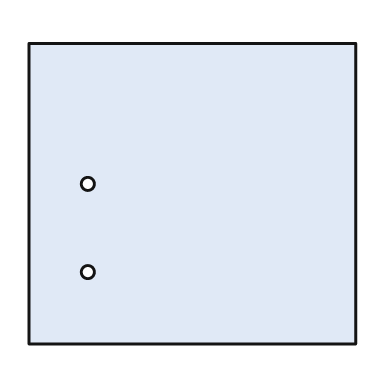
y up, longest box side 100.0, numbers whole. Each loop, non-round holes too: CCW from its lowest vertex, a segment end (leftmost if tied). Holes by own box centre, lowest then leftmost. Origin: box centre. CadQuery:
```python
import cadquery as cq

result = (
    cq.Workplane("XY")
    .moveTo(-50.0, -46.0)
    .lineTo(50.0, -46.0)
    .lineTo(50.0, 46.0)
    .lineTo(-50.0, 46.0)
    .close()
    .moveTo(-32.0, -24.0)
    .circle(2.0)
    .moveTo(-32.0, 3.0)
    .circle(2.0)
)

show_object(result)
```